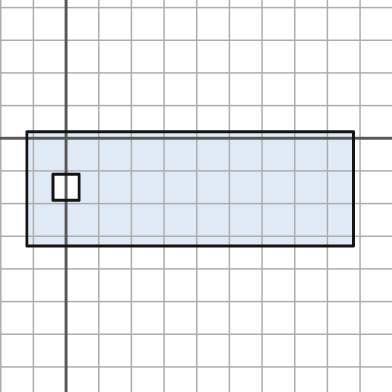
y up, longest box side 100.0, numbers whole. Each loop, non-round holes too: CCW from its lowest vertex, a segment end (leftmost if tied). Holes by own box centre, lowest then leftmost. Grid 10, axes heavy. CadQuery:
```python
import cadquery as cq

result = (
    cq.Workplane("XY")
    .moveTo(-12.0, -33.0)
    .lineTo(88.0, -33.0)
    .lineTo(88.0, 2.0)
    .lineTo(-12.0, 2.0)
    .close()
    .moveTo(-4.0, -19.0)
    .lineTo(4.0, -19.0)
    .lineTo(4.0, -11.0)
    .lineTo(-4.0, -11.0)
    .close()
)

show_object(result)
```